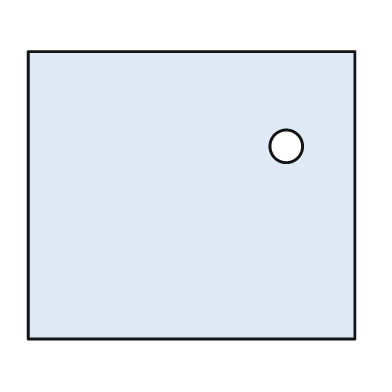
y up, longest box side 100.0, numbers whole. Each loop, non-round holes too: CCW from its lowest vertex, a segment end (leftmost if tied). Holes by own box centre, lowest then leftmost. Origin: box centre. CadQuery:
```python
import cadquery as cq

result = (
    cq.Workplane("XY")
    .moveTo(-50.0, -44.0)
    .lineTo(50.0, -44.0)
    .lineTo(50.0, 44.0)
    .lineTo(-50.0, 44.0)
    .close()
    .moveTo(29.0, 15.0)
    .circle(5.0)
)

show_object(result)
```